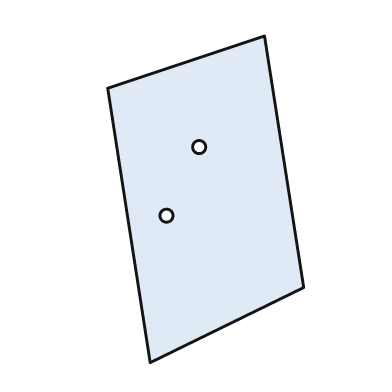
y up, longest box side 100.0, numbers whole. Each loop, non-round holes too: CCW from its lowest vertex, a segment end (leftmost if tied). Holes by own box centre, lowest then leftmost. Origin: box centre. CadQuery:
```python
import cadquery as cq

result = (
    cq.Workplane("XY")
    .moveTo(-17.0, -50.0)
    .lineTo(30.0, -27.0)
    .lineTo(18.0, 50.0)
    .lineTo(-30.0, 34.0)
    .close()
    .moveTo(-12.0, -5.0)
    .circle(2.0)
    .moveTo(-2.0, 16.0)
    .circle(2.0)
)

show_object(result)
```